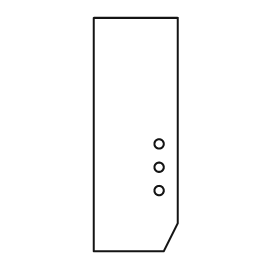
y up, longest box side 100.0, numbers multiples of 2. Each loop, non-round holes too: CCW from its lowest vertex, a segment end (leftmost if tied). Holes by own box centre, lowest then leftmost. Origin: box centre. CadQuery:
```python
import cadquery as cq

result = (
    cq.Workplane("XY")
    .moveTo(-18.0, -50.0)
    .lineTo(12.0, -50.0)
    .lineTo(18.0, -38.0)
    .lineTo(18.0, 50.0)
    .lineTo(-18.0, 50.0)
    .close()
    .moveTo(10.0, -24.0)
    .circle(2.0)
    .moveTo(10.0, -14.0)
    .circle(2.0)
    .moveTo(10.0, -4.0)
    .circle(2.0)
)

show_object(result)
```